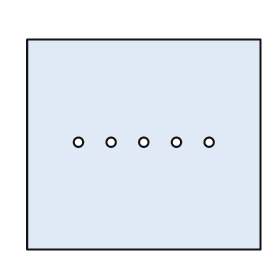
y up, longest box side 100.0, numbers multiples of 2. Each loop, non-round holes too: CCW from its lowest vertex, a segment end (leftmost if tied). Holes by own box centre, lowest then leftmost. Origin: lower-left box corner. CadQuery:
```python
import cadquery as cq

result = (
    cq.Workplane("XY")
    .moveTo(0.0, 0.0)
    .lineTo(100.0, 0.0)
    .lineTo(100.0, 90.0)
    .lineTo(0.0, 90.0)
    .close()
    .moveTo(22.0, 46.0)
    .circle(2.0)
    .moveTo(36.0, 46.0)
    .circle(2.0)
    .moveTo(50.0, 46.0)
    .circle(2.0)
    .moveTo(64.0, 46.0)
    .circle(2.0)
    .moveTo(78.0, 46.0)
    .circle(2.0)
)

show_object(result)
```